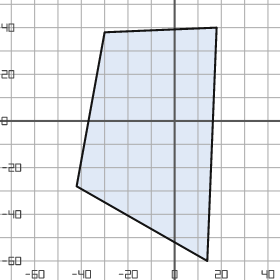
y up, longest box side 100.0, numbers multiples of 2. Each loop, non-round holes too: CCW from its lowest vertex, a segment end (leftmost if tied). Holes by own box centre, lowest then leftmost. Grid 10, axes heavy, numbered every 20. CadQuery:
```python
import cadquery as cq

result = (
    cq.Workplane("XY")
    .moveTo(14.0, -60.0)
    .lineTo(18.0, 40.0)
    .lineTo(-30.0, 38.0)
    .lineTo(-42.0, -28.0)
    .close()
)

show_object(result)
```